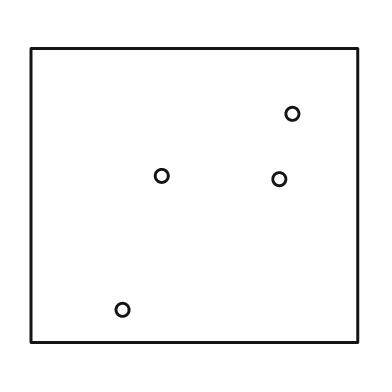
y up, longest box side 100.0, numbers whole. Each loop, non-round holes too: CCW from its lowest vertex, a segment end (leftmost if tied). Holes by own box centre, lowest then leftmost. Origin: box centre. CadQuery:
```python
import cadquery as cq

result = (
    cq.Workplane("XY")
    .moveTo(-50.0, -45.0)
    .lineTo(50.0, -45.0)
    .lineTo(50.0, 45.0)
    .lineTo(-50.0, 45.0)
    .close()
    .moveTo(-22.0, -35.0)
    .circle(2.0)
    .moveTo(26.0, 5.0)
    .circle(2.0)
    .moveTo(-10.0, 6.0)
    .circle(2.0)
    .moveTo(30.0, 25.0)
    .circle(2.0)
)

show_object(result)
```